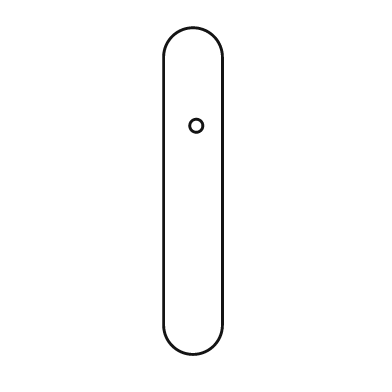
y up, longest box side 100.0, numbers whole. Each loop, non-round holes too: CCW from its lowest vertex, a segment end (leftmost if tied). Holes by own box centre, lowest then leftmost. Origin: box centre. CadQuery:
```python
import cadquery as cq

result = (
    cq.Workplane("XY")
    .moveTo(-9.0, -41.0)
    .threePointArc((0.0, -50.0), (9.0, -41.0))
    .lineTo(9.0, 41.0)
    .threePointArc((0.0, 50.0), (-9.0, 41.0))
    .close()
    .moveTo(1.0, 20.0)
    .circle(2.0)
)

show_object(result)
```